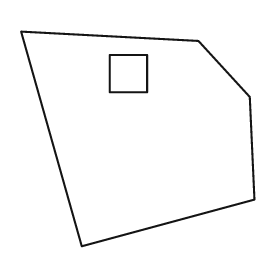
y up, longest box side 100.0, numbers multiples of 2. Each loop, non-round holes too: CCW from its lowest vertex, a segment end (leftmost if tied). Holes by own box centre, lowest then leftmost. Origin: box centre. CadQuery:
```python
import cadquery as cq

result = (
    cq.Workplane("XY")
    .moveTo(-24.0, -46.0)
    .lineTo(50.0, -26.0)
    .lineTo(48.0, 18.0)
    .lineTo(26.0, 42.0)
    .lineTo(-50.0, 46.0)
    .close()
    .moveTo(-12.0, 20.0)
    .lineTo(4.0, 20.0)
    .lineTo(4.0, 36.0)
    .lineTo(-12.0, 36.0)
    .close()
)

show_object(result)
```